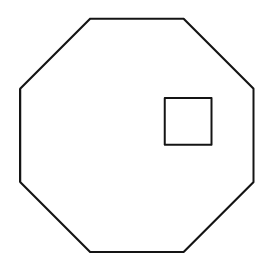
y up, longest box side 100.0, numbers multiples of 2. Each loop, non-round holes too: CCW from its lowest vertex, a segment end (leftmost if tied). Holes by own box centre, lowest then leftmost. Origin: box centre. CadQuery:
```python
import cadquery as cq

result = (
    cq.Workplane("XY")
    .moveTo(-20.0, -50.0)
    .lineTo(20.0, -50.0)
    .lineTo(50.0, -20.0)
    .lineTo(50.0, 20.0)
    .lineTo(20.0, 50.0)
    .lineTo(-20.0, 50.0)
    .lineTo(-50.0, 20.0)
    .lineTo(-50.0, -20.0)
    .close()
    .moveTo(12.0, -4.0)
    .lineTo(32.0, -4.0)
    .lineTo(32.0, 16.0)
    .lineTo(12.0, 16.0)
    .close()
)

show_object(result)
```